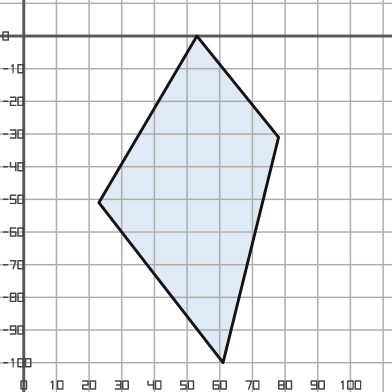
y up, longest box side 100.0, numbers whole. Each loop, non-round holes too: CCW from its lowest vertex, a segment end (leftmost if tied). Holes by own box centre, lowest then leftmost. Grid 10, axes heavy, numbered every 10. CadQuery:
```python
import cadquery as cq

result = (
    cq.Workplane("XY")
    .moveTo(61.0, -100.0)
    .lineTo(78.0, -31.0)
    .lineTo(53.0, 0.0)
    .lineTo(23.0, -51.0)
    .close()
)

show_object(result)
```